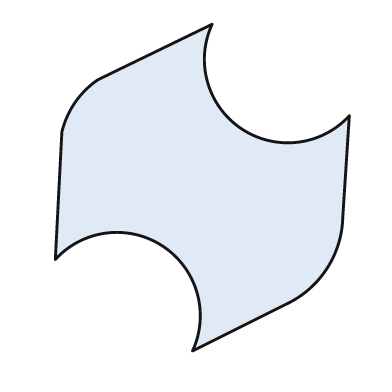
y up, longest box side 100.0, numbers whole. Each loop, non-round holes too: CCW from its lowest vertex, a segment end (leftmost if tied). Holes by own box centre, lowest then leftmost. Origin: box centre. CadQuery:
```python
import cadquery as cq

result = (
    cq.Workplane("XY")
    .moveTo(-3.0, -50.0)
    .lineTo(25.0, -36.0)
    .threePointArc((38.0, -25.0), (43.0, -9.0))
    .lineTo(45.0, 22.0)
    .threePointArc((12.0, 18.0), (3.0, 50.0))
    .lineTo(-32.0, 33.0)
    .threePointArc((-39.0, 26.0), (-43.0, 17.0))
    .lineTo(-45.0, -22.0)
    .threePointArc((-12.0, -18.0), (-3.0, -50.0))
    .close()
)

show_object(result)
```